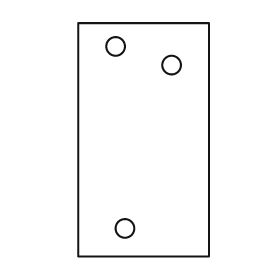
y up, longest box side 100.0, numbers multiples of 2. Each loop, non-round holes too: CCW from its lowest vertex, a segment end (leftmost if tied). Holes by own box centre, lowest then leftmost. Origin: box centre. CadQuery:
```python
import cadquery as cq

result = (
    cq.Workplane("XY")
    .moveTo(-28.0, -50.0)
    .lineTo(28.0, -50.0)
    .lineTo(28.0, 50.0)
    .lineTo(-28.0, 50.0)
    .close()
    .moveTo(-8.0, -38.0)
    .circle(4.0)
    .moveTo(12.0, 32.0)
    .circle(4.0)
    .moveTo(-12.0, 40.0)
    .circle(4.0)
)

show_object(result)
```